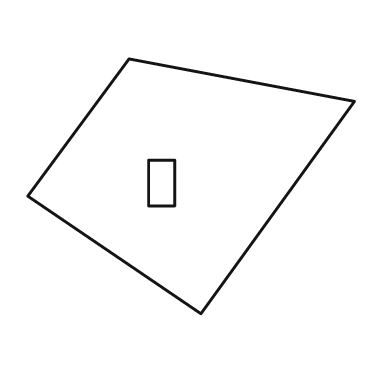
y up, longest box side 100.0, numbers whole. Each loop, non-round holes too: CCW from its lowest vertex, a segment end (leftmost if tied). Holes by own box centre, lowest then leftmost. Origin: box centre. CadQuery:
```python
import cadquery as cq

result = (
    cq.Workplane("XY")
    .moveTo(3.0, -39.0)
    .lineTo(50.0, 26.0)
    .lineTo(-19.0, 39.0)
    .lineTo(-50.0, -3.0)
    .close()
    .moveTo(-13.0, -6.0)
    .lineTo(-5.0, -6.0)
    .lineTo(-5.0, 8.0)
    .lineTo(-13.0, 8.0)
    .close()
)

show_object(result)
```